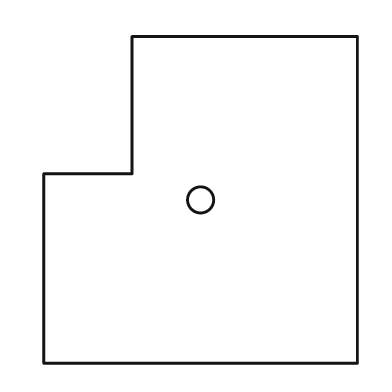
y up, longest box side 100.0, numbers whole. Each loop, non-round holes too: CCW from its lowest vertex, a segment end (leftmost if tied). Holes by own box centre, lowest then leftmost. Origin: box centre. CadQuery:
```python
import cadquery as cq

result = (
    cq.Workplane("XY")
    .moveTo(-48.0, -50.0)
    .lineTo(48.0, -50.0)
    .lineTo(48.0, 50.0)
    .lineTo(-21.0, 50.0)
    .lineTo(-21.0, 8.0)
    .lineTo(-48.0, 8.0)
    .close()
    .moveTo(0.0, 0.0)
    .circle(4.0)
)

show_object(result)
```